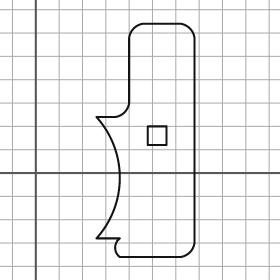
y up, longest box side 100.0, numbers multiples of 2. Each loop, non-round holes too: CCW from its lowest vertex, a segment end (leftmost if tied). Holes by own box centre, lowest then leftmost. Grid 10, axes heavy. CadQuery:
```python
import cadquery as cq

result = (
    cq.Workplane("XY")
    .moveTo(36.0, -36.0)
    .lineTo(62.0, -36.0)
    .threePointArc((66.0, -34.0), (68.0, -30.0))
    .lineTo(68.0, 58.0)
    .threePointArc((66.0, 62.0), (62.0, 64.0))
    .lineTo(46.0, 64.0)
    .threePointArc((42.0, 62.0), (40.0, 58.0))
    .lineTo(40.0, 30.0)
    .threePointArc((38.0, 26.0), (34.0, 24.0))
    .lineTo(26.0, 24.0)
    .threePointArc((36.0, -2.0), (26.0, -28.0))
    .lineTo(36.0, -28.0)
    .threePointArc((34.0, -32.0), (36.0, -36.0))
    .close()
    .moveTo(48.0, 12.0)
    .lineTo(56.0, 12.0)
    .lineTo(56.0, 20.0)
    .lineTo(48.0, 20.0)
    .close()
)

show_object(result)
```